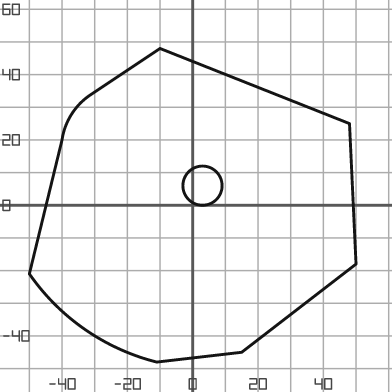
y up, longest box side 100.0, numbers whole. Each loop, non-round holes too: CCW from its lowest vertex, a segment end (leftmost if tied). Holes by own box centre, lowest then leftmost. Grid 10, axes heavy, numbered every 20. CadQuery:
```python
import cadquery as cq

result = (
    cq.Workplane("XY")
    .moveTo(-11.0, -48.0)
    .lineTo(15.0, -45.0)
    .lineTo(50.0, -18.0)
    .lineTo(48.0, 25.0)
    .lineTo(-10.0, 48.0)
    .lineTo(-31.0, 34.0)
    .threePointArc((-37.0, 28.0), (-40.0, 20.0))
    .lineTo(-50.0, -21.0)
    .threePointArc((-33.0, -38.0), (-11.0, -48.0))
    .close()
    .moveTo(3.0, 6.0)
    .circle(6.0)
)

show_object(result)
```